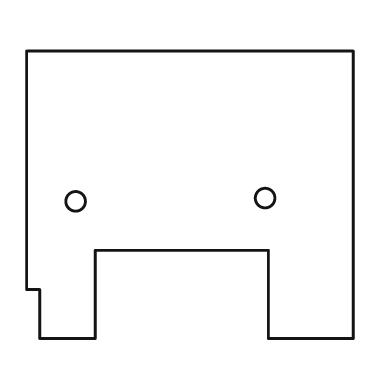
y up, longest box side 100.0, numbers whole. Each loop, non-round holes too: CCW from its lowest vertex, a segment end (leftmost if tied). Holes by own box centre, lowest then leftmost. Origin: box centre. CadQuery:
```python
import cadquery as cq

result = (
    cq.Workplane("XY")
    .moveTo(-46.0, -44.0)
    .lineTo(-29.0, -44.0)
    .lineTo(-29.0, -17.0)
    .lineTo(24.0, -17.0)
    .lineTo(24.0, -44.0)
    .lineTo(50.0, -44.0)
    .lineTo(50.0, 44.0)
    .lineTo(-50.0, 44.0)
    .lineTo(-50.0, -29.0)
    .lineTo(-46.0, -29.0)
    .close()
    .moveTo(-35.0, -2.0)
    .circle(3.0)
    .moveTo(23.0, -1.0)
    .circle(3.0)
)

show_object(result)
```